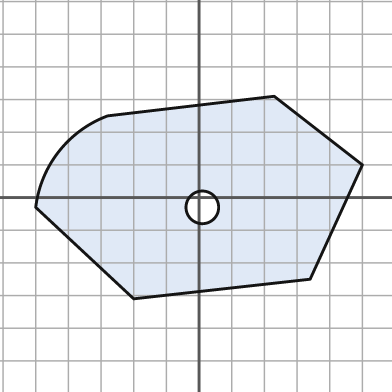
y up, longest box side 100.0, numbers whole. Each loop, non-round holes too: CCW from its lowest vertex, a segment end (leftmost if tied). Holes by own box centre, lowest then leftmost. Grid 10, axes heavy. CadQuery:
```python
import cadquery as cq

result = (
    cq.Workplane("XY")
    .moveTo(-20.0, -31.0)
    .lineTo(34.0, -25.0)
    .lineTo(50.0, 10.0)
    .lineTo(23.0, 31.0)
    .lineTo(-28.0, 25.0)
    .threePointArc((-43.0, 14.0), (-50.0, -3.0))
    .close()
    .moveTo(1.0, -3.0)
    .circle(5.0)
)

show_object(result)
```